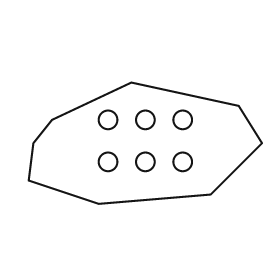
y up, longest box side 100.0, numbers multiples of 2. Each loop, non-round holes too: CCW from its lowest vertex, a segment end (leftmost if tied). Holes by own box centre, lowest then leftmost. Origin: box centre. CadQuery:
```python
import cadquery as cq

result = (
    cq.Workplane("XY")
    .moveTo(-20.0, -26.0)
    .lineTo(28.0, -22.0)
    .lineTo(50.0, 0.0)
    .lineTo(40.0, 16.0)
    .lineTo(-6.0, 26.0)
    .lineTo(-40.0, 10.0)
    .lineTo(-48.0, 0.0)
    .lineTo(-50.0, -16.0)
    .close()
    .moveTo(-16.0, -8.0)
    .circle(4.0)
    .moveTo(0.0, -8.0)
    .circle(4.0)
    .moveTo(16.0, -8.0)
    .circle(4.0)
    .moveTo(-16.0, 10.0)
    .circle(4.0)
    .moveTo(0.0, 10.0)
    .circle(4.0)
    .moveTo(16.0, 10.0)
    .circle(4.0)
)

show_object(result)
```